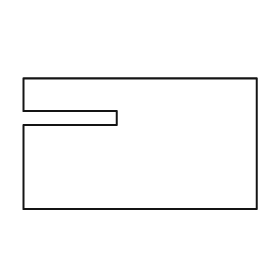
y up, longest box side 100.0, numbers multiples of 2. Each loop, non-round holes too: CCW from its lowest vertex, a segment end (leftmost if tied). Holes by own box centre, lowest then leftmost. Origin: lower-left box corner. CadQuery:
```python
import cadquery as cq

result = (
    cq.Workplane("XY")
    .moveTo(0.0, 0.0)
    .lineTo(100.0, 0.0)
    .lineTo(100.0, 56.0)
    .lineTo(0.0, 56.0)
    .lineTo(0.0, 42.0)
    .lineTo(40.0, 42.0)
    .lineTo(40.0, 36.0)
    .lineTo(0.0, 36.0)
    .close()
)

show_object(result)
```